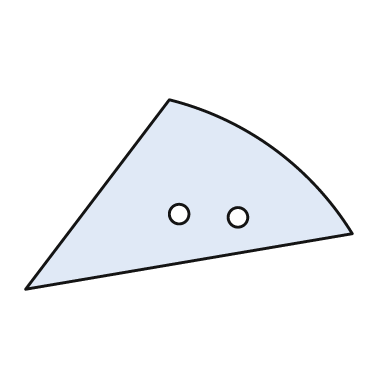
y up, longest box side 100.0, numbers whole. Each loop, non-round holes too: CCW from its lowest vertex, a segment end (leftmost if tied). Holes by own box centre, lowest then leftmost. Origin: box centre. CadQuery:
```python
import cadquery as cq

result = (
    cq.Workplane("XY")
    .moveTo(-50.0, -29.0)
    .lineTo(50.0, -12.0)
    .threePointArc((26.0, 14.0), (-6.0, 29.0))
    .close()
    .moveTo(15.0, -7.0)
    .circle(3.0)
    .moveTo(-3.0, -6.0)
    .circle(3.0)
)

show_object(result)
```